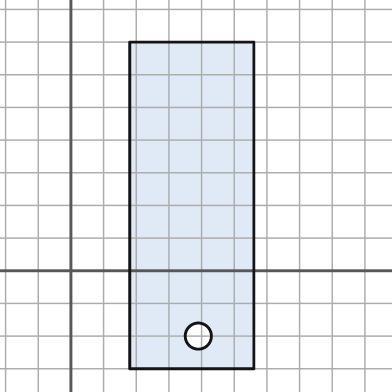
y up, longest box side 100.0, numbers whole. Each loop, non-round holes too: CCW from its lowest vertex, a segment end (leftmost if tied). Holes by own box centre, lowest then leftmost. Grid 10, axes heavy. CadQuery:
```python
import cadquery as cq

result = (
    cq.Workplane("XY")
    .moveTo(18.0, -30.0)
    .lineTo(56.0, -30.0)
    .lineTo(56.0, 70.0)
    .lineTo(18.0, 70.0)
    .close()
    .moveTo(39.0, -20.0)
    .circle(4.0)
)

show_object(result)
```